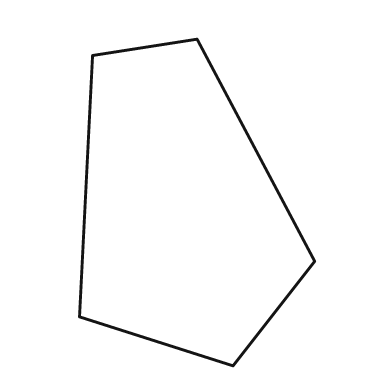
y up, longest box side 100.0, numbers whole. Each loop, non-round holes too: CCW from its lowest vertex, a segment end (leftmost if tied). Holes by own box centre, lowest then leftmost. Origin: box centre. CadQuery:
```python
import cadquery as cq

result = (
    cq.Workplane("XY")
    .moveTo(11.0, -50.0)
    .lineTo(36.0, -18.0)
    .lineTo(0.0, 50.0)
    .lineTo(-32.0, 45.0)
    .lineTo(-36.0, -35.0)
    .close()
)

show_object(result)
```